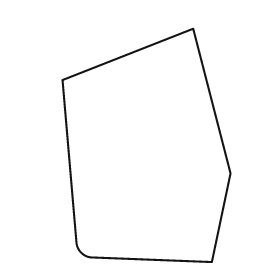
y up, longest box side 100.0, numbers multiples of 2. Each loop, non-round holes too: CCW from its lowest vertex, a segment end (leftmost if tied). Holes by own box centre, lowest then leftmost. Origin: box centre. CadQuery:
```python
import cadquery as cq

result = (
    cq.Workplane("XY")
    .moveTo(28.0, -50.0)
    .lineTo(36.0, -12.0)
    .lineTo(20.0, 50.0)
    .lineTo(-36.0, 28.0)
    .lineTo(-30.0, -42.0)
    .threePointArc((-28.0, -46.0), (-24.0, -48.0))
    .close()
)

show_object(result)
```